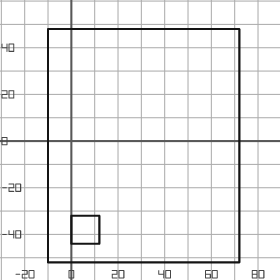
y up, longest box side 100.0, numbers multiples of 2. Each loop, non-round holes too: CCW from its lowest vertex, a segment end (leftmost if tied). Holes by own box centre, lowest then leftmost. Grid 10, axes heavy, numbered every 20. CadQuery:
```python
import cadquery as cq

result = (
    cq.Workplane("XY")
    .moveTo(-10.0, -52.0)
    .lineTo(72.0, -52.0)
    .lineTo(72.0, 48.0)
    .lineTo(-10.0, 48.0)
    .close()
    .moveTo(0.0, -44.0)
    .lineTo(12.0, -44.0)
    .lineTo(12.0, -32.0)
    .lineTo(0.0, -32.0)
    .close()
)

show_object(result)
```